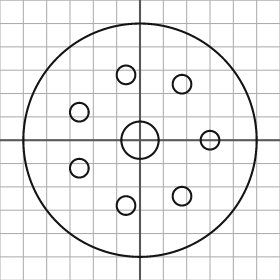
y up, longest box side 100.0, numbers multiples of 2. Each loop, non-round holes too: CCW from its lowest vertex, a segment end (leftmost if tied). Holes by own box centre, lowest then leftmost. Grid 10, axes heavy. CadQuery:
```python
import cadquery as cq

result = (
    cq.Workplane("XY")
    .moveTo(0.0, 0.0)
    .circle(50.0)
    .moveTo(-6.0, -28.0)
    .circle(4.0)
    .moveTo(18.0, -24.0)
    .circle(4.0)
    .moveTo(-26.0, -12.0)
    .circle(4.0)
    .moveTo(0.0, 0.0)
    .circle(8.0)
    .moveTo(30.0, 0.0)
    .circle(4.0)
    .moveTo(-26.0, 12.0)
    .circle(4.0)
    .moveTo(18.0, 24.0)
    .circle(4.0)
    .moveTo(-6.0, 28.0)
    .circle(4.0)
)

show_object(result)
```